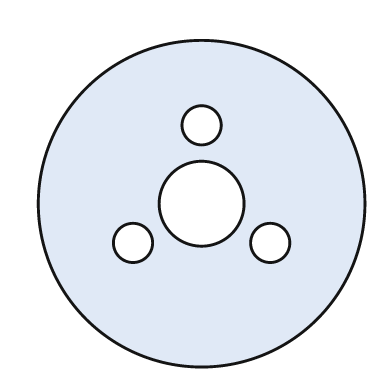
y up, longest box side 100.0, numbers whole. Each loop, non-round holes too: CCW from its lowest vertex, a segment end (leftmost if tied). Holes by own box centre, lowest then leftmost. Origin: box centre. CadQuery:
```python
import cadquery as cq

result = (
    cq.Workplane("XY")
    .moveTo(0.0, 0.0)
    .circle(50.0)
    .moveTo(-21.0, -12.0)
    .circle(6.0)
    .moveTo(21.0, -12.0)
    .circle(6.0)
    .moveTo(0.0, 0.0)
    .circle(13.0)
    .moveTo(0.0, 24.0)
    .circle(6.0)
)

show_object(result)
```